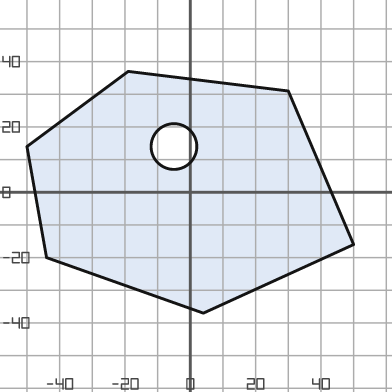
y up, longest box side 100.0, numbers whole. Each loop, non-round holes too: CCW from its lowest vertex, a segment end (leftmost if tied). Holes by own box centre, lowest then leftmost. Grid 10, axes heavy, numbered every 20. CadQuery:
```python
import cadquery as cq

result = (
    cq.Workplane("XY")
    .moveTo(4.0, -37.0)
    .lineTo(50.0, -16.0)
    .lineTo(30.0, 31.0)
    .lineTo(-19.0, 37.0)
    .lineTo(-50.0, 14.0)
    .lineTo(-44.0, -20.0)
    .close()
    .moveTo(-5.0, 14.0)
    .circle(7.0)
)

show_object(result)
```